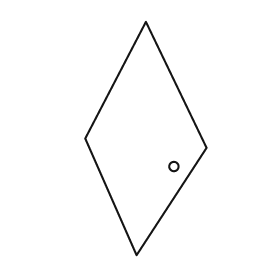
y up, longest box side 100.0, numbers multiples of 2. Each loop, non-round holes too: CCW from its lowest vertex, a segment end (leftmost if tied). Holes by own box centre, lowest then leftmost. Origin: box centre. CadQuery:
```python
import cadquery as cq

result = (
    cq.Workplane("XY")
    .moveTo(-4.0, -50.0)
    .lineTo(26.0, -4.0)
    .lineTo(0.0, 50.0)
    .lineTo(-26.0, 0.0)
    .close()
    .moveTo(12.0, -12.0)
    .circle(2.0)
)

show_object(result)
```